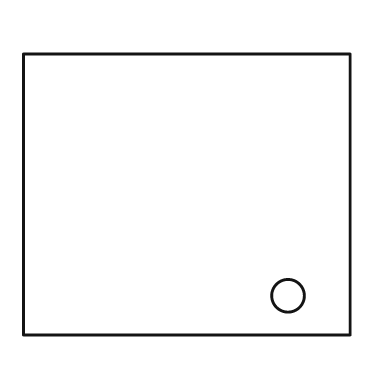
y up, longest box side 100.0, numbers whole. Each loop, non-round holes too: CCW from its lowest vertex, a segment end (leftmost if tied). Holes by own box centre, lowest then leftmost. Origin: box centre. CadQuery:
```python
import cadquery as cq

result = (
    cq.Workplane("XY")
    .moveTo(-50.0, -43.0)
    .lineTo(50.0, -43.0)
    .lineTo(50.0, 43.0)
    .lineTo(-50.0, 43.0)
    .close()
    .moveTo(31.0, -31.0)
    .circle(5.0)
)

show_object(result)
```